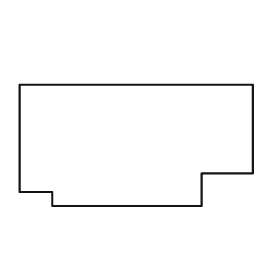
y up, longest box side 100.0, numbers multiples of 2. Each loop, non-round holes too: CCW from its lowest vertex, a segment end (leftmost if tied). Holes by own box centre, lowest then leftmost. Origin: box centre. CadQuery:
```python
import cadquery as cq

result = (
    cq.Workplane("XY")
    .moveTo(-36.0, -26.0)
    .lineTo(28.0, -26.0)
    .lineTo(28.0, -12.0)
    .lineTo(50.0, -12.0)
    .lineTo(50.0, 26.0)
    .lineTo(-50.0, 26.0)
    .lineTo(-50.0, -20.0)
    .lineTo(-36.0, -20.0)
    .close()
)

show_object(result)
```